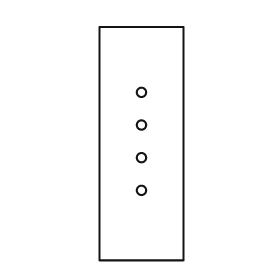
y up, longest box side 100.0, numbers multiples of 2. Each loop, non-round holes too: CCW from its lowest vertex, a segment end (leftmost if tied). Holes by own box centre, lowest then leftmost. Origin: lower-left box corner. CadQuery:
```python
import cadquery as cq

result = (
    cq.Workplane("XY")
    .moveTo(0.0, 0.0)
    .lineTo(36.0, 0.0)
    .lineTo(36.0, 100.0)
    .lineTo(0.0, 100.0)
    .close()
    .moveTo(18.0, 30.0)
    .circle(2.0)
    .moveTo(18.0, 44.0)
    .circle(2.0)
    .moveTo(18.0, 58.0)
    .circle(2.0)
    .moveTo(18.0, 72.0)
    .circle(2.0)
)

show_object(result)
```